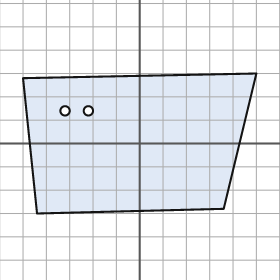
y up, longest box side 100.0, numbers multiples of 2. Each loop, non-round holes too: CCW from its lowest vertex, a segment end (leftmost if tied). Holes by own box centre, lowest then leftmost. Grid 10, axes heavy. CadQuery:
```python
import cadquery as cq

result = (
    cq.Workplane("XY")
    .moveTo(-44.0, -30.0)
    .lineTo(36.0, -28.0)
    .lineTo(50.0, 30.0)
    .lineTo(-50.0, 28.0)
    .close()
    .moveTo(-32.0, 14.0)
    .circle(2.0)
    .moveTo(-22.0, 14.0)
    .circle(2.0)
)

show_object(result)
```